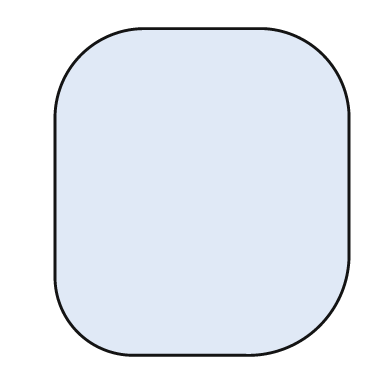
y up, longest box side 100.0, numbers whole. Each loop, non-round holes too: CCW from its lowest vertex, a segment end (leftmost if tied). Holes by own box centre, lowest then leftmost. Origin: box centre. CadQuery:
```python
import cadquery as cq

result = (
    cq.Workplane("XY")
    .moveTo(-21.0, -50.0)
    .lineTo(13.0, -50.0)
    .threePointArc((36.0, -41.0), (45.0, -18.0))
    .lineTo(45.0, 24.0)
    .threePointArc((37.0, 42.0), (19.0, 50.0))
    .lineTo(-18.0, 50.0)
    .threePointArc((-37.0, 42.0), (-45.0, 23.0))
    .lineTo(-45.0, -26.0)
    .threePointArc((-38.0, -43.0), (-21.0, -50.0))
    .close()
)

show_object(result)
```